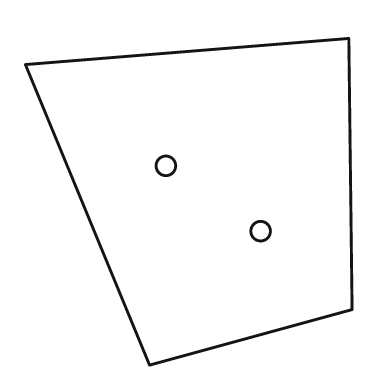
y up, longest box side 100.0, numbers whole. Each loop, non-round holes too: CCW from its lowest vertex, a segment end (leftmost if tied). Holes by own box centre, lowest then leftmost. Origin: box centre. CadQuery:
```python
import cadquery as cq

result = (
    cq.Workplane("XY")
    .moveTo(-12.0, -50.0)
    .lineTo(50.0, -33.0)
    .lineTo(49.0, 50.0)
    .lineTo(-50.0, 42.0)
    .close()
    .moveTo(22.0, -9.0)
    .circle(3.0)
    .moveTo(-7.0, 11.0)
    .circle(3.0)
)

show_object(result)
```